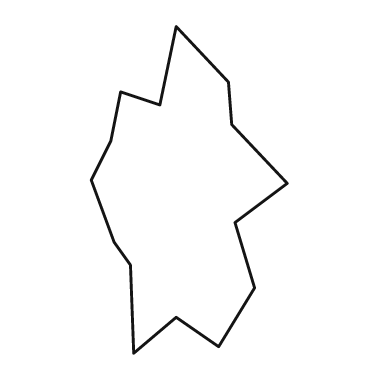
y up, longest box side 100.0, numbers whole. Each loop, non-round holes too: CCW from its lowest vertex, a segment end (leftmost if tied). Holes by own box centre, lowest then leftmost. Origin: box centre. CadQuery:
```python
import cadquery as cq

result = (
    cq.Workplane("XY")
    .moveTo(-17.0, -50.0)
    .lineTo(-4.0, -39.0)
    .lineTo(9.0, -48.0)
    .lineTo(20.0, -30.0)
    .lineTo(14.0, -10.0)
    .lineTo(30.0, 2.0)
    .lineTo(13.0, 20.0)
    .lineTo(12.0, 33.0)
    .lineTo(-4.0, 50.0)
    .lineTo(-9.0, 26.0)
    .lineTo(-21.0, 30.0)
    .lineTo(-24.0, 15.0)
    .lineTo(-30.0, 3.0)
    .lineTo(-23.0, -16.0)
    .lineTo(-18.0, -23.0)
    .close()
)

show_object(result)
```